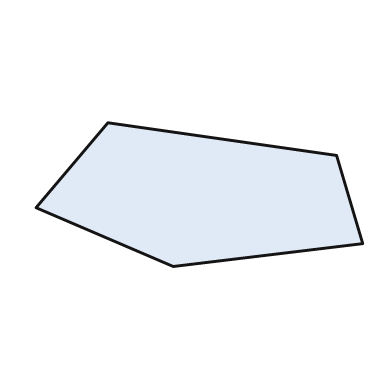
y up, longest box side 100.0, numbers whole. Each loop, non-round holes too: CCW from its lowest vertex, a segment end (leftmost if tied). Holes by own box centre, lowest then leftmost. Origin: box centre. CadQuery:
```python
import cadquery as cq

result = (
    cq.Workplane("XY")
    .moveTo(-8.0, -22.0)
    .lineTo(50.0, -15.0)
    .lineTo(42.0, 12.0)
    .lineTo(-28.0, 22.0)
    .lineTo(-50.0, -4.0)
    .close()
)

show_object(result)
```